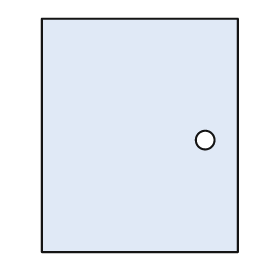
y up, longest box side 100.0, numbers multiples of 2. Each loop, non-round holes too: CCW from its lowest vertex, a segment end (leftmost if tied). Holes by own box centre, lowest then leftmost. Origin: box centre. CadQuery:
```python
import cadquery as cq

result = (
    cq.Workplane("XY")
    .moveTo(-42.0, -50.0)
    .lineTo(42.0, -50.0)
    .lineTo(42.0, 50.0)
    .lineTo(-42.0, 50.0)
    .close()
    .moveTo(28.0, -2.0)
    .circle(4.0)
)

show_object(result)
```